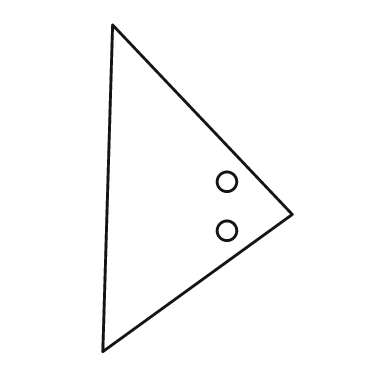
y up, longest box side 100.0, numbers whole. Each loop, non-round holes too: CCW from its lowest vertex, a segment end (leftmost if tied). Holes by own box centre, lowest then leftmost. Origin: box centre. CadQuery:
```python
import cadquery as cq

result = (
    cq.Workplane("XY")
    .moveTo(-29.0, -50.0)
    .lineTo(29.0, -8.0)
    .lineTo(-26.0, 50.0)
    .close()
    .moveTo(9.0, -13.0)
    .circle(3.0)
    .moveTo(9.0, 2.0)
    .circle(3.0)
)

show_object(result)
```